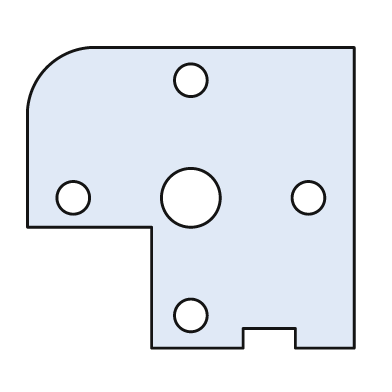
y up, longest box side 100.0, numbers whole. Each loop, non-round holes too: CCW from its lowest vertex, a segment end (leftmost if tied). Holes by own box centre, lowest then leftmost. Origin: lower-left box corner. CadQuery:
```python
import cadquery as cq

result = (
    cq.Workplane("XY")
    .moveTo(38.0, 0.0)
    .lineTo(66.0, 0.0)
    .lineTo(66.0, 6.0)
    .lineTo(82.0, 6.0)
    .lineTo(82.0, 0.0)
    .lineTo(100.0, 0.0)
    .lineTo(100.0, 92.0)
    .lineTo(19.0, 92.0)
    .threePointArc((6.0, 86.0), (0.0, 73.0))
    .lineTo(0.0, 37.0)
    .lineTo(38.0, 37.0)
    .close()
    .moveTo(50.0, 10.0)
    .circle(5.0)
    .moveTo(14.0, 46.0)
    .circle(5.0)
    .moveTo(50.0, 46.0)
    .circle(9.0)
    .moveTo(86.0, 46.0)
    .circle(5.0)
    .moveTo(50.0, 82.0)
    .circle(5.0)
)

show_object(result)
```